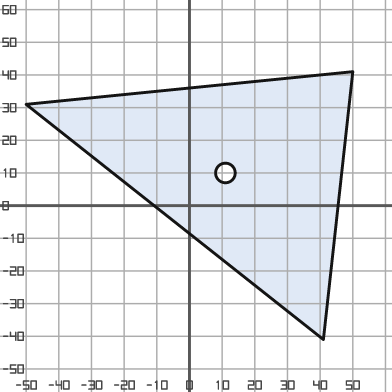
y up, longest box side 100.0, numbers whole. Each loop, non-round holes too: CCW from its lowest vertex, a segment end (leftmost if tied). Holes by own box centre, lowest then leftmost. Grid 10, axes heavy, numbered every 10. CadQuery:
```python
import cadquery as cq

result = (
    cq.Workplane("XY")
    .moveTo(41.0, -41.0)
    .lineTo(50.0, 41.0)
    .lineTo(-50.0, 31.0)
    .close()
    .moveTo(11.0, 10.0)
    .circle(3.0)
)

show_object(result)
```